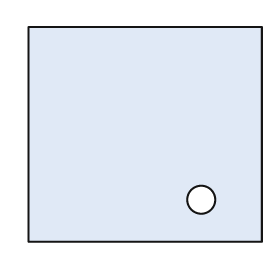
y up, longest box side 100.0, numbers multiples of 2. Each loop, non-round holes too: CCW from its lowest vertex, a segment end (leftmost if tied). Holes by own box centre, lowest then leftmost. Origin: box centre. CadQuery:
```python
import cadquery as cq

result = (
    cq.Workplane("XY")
    .moveTo(-50.0, -46.0)
    .lineTo(50.0, -46.0)
    .lineTo(50.0, 46.0)
    .lineTo(-50.0, 46.0)
    .close()
    .moveTo(24.0, -28.0)
    .circle(6.0)
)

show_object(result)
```